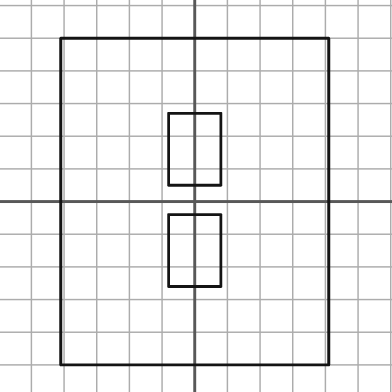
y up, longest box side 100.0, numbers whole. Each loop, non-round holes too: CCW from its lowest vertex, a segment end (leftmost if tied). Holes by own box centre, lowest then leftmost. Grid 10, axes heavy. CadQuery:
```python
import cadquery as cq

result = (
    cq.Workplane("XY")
    .moveTo(-41.0, -50.0)
    .lineTo(41.0, -50.0)
    .lineTo(41.0, 50.0)
    .lineTo(-41.0, 50.0)
    .close()
    .moveTo(-8.0, -26.0)
    .lineTo(8.0, -26.0)
    .lineTo(8.0, -4.0)
    .lineTo(-8.0, -4.0)
    .close()
    .moveTo(-8.0, 5.0)
    .lineTo(8.0, 5.0)
    .lineTo(8.0, 27.0)
    .lineTo(-8.0, 27.0)
    .close()
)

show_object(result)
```